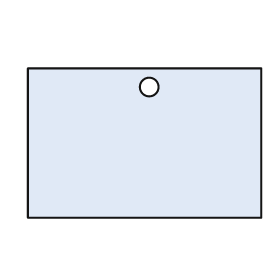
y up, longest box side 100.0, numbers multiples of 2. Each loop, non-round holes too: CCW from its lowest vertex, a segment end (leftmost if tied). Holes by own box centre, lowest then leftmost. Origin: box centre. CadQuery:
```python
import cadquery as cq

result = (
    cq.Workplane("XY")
    .moveTo(-50.0, -32.0)
    .lineTo(50.0, -32.0)
    .lineTo(50.0, 32.0)
    .lineTo(-50.0, 32.0)
    .close()
    .moveTo(2.0, 24.0)
    .circle(4.0)
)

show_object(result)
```